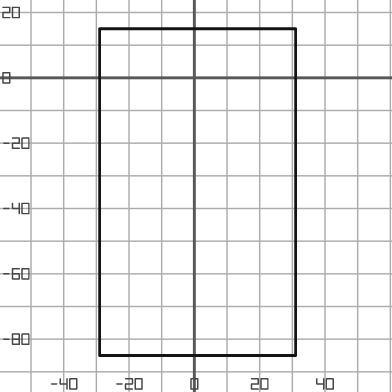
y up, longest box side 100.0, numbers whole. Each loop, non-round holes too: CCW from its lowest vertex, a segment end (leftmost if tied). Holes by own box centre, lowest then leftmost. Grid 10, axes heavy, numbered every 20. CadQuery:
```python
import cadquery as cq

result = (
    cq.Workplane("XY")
    .moveTo(-29.0, -85.0)
    .lineTo(31.0, -85.0)
    .lineTo(31.0, 15.0)
    .lineTo(-29.0, 15.0)
    .close()
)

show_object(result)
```